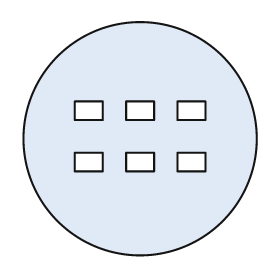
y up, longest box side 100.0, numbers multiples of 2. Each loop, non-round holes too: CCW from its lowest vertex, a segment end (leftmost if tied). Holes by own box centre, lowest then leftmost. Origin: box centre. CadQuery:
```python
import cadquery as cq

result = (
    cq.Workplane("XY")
    .moveTo(0.0, 0.0)
    .circle(50.0)
    .moveTo(-28.0, -14.0)
    .lineTo(-16.0, -14.0)
    .lineTo(-16.0, -6.0)
    .lineTo(-28.0, -6.0)
    .close()
    .moveTo(-6.0, -14.0)
    .lineTo(6.0, -14.0)
    .lineTo(6.0, -6.0)
    .lineTo(-6.0, -6.0)
    .close()
    .moveTo(16.0, -14.0)
    .lineTo(28.0, -14.0)
    .lineTo(28.0, -6.0)
    .lineTo(16.0, -6.0)
    .close()
    .moveTo(-28.0, 8.0)
    .lineTo(-16.0, 8.0)
    .lineTo(-16.0, 16.0)
    .lineTo(-28.0, 16.0)
    .close()
    .moveTo(-6.0, 8.0)
    .lineTo(6.0, 8.0)
    .lineTo(6.0, 16.0)
    .lineTo(-6.0, 16.0)
    .close()
    .moveTo(16.0, 8.0)
    .lineTo(28.0, 8.0)
    .lineTo(28.0, 16.0)
    .lineTo(16.0, 16.0)
    .close()
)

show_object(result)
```